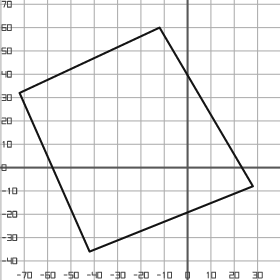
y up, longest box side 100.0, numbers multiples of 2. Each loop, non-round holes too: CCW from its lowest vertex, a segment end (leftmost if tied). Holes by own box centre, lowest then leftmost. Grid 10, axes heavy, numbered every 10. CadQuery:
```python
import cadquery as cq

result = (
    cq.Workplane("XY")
    .moveTo(-42.0, -36.0)
    .lineTo(28.0, -8.0)
    .lineTo(-12.0, 60.0)
    .lineTo(-72.0, 32.0)
    .close()
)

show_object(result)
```